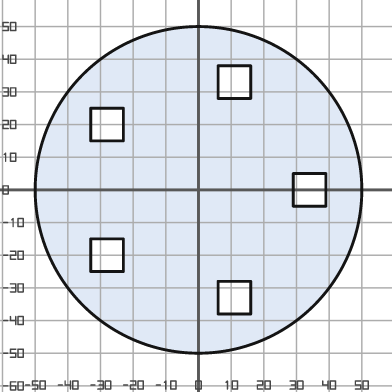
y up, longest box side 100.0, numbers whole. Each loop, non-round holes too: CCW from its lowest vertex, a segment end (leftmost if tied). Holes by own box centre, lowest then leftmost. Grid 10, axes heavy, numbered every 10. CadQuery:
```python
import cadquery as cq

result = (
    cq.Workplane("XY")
    .moveTo(0.0, 0.0)
    .circle(50.0)
    .moveTo(6.0, -38.0)
    .lineTo(16.0, -38.0)
    .lineTo(16.0, -28.0)
    .lineTo(6.0, -28.0)
    .close()
    .moveTo(-33.0, -25.0)
    .lineTo(-23.0, -25.0)
    .lineTo(-23.0, -15.0)
    .lineTo(-33.0, -15.0)
    .close()
    .moveTo(29.0, -5.0)
    .lineTo(39.0, -5.0)
    .lineTo(39.0, 5.0)
    .lineTo(29.0, 5.0)
    .close()
    .moveTo(-33.0, 15.0)
    .lineTo(-23.0, 15.0)
    .lineTo(-23.0, 25.0)
    .lineTo(-33.0, 25.0)
    .close()
    .moveTo(6.0, 28.0)
    .lineTo(16.0, 28.0)
    .lineTo(16.0, 38.0)
    .lineTo(6.0, 38.0)
    .close()
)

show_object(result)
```